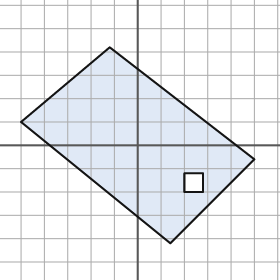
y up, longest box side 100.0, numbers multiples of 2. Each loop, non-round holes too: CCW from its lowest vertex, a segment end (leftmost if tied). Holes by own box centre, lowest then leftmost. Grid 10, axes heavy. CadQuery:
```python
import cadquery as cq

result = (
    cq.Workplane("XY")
    .moveTo(14.0, -42.0)
    .lineTo(50.0, -6.0)
    .lineTo(-12.0, 42.0)
    .lineTo(-50.0, 10.0)
    .close()
    .moveTo(20.0, -20.0)
    .lineTo(28.0, -20.0)
    .lineTo(28.0, -12.0)
    .lineTo(20.0, -12.0)
    .close()
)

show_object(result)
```